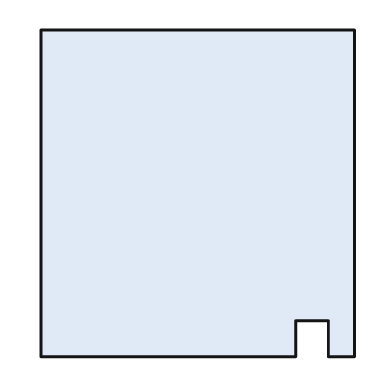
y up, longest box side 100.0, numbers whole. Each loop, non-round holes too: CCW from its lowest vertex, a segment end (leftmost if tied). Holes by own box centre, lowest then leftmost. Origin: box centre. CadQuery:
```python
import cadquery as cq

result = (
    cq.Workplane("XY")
    .moveTo(-48.0, -50.0)
    .lineTo(30.0, -50.0)
    .lineTo(30.0, -39.0)
    .lineTo(40.0, -39.0)
    .lineTo(40.0, -50.0)
    .lineTo(48.0, -50.0)
    .lineTo(48.0, 50.0)
    .lineTo(-48.0, 50.0)
    .close()
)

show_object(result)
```